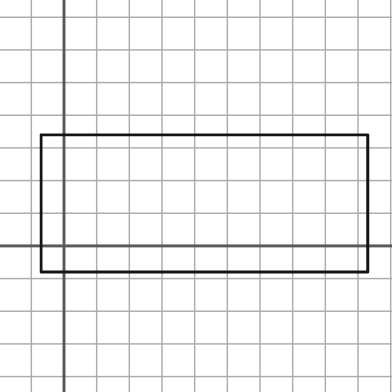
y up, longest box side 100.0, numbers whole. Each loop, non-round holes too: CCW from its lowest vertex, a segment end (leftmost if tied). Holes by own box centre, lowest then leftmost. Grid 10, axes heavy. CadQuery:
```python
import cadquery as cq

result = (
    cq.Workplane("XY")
    .moveTo(-7.0, -8.0)
    .lineTo(93.0, -8.0)
    .lineTo(93.0, 34.0)
    .lineTo(-7.0, 34.0)
    .close()
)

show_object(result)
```